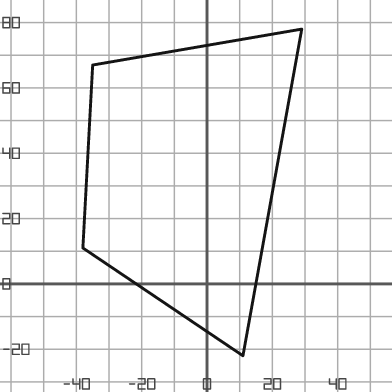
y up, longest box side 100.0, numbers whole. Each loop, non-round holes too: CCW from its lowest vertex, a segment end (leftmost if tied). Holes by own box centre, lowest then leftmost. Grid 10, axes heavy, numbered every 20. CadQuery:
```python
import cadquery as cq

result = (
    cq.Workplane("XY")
    .moveTo(11.0, -22.0)
    .lineTo(29.0, 78.0)
    .lineTo(-35.0, 67.0)
    .lineTo(-38.0, 11.0)
    .close()
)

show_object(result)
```